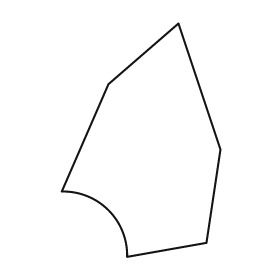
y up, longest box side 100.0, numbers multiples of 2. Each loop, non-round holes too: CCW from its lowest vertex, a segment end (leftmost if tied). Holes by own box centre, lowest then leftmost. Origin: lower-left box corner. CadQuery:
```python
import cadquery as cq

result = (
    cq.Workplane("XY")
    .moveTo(28.0, 0.0)
    .lineTo(62.0, 6.0)
    .lineTo(68.0, 46.0)
    .lineTo(50.0, 100.0)
    .lineTo(20.0, 74.0)
    .lineTo(0.0, 28.0)
    .threePointArc((20.0, 20.0), (28.0, 0.0))
    .close()
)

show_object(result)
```